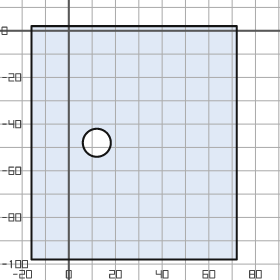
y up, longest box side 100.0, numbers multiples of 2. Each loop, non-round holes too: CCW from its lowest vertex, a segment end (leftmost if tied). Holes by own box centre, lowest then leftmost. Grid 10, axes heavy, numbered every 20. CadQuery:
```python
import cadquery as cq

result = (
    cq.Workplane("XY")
    .moveTo(-16.0, -98.0)
    .lineTo(72.0, -98.0)
    .lineTo(72.0, 2.0)
    .lineTo(-16.0, 2.0)
    .close()
    .moveTo(12.0, -48.0)
    .circle(6.0)
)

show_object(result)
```